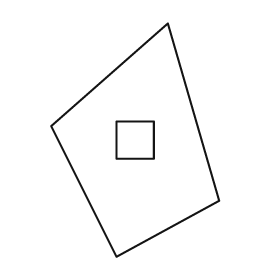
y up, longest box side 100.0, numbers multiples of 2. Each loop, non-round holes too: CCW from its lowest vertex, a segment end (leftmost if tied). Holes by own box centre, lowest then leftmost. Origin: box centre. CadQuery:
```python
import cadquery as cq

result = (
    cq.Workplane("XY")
    .moveTo(-8.0, -50.0)
    .lineTo(36.0, -26.0)
    .lineTo(14.0, 50.0)
    .lineTo(-36.0, 6.0)
    .close()
    .moveTo(-8.0, -8.0)
    .lineTo(8.0, -8.0)
    .lineTo(8.0, 8.0)
    .lineTo(-8.0, 8.0)
    .close()
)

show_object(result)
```